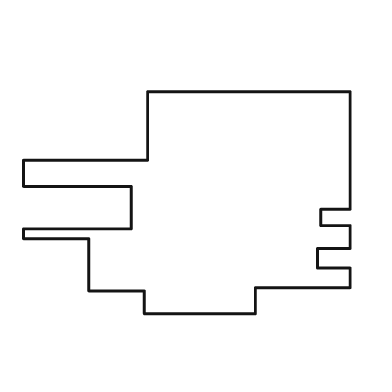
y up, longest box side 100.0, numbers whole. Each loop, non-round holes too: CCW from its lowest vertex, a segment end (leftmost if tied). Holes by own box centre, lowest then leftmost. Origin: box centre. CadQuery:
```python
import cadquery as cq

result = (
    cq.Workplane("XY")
    .moveTo(-13.0, -34.0)
    .lineTo(21.0, -34.0)
    .lineTo(21.0, -26.0)
    .lineTo(50.0, -26.0)
    .lineTo(50.0, -20.0)
    .lineTo(40.0, -20.0)
    .lineTo(40.0, -14.0)
    .lineTo(50.0, -14.0)
    .lineTo(50.0, -7.0)
    .lineTo(41.0, -7.0)
    .lineTo(41.0, -2.0)
    .lineTo(50.0, -2.0)
    .lineTo(50.0, 34.0)
    .lineTo(-12.0, 34.0)
    .lineTo(-12.0, 13.0)
    .lineTo(-50.0, 13.0)
    .lineTo(-50.0, 5.0)
    .lineTo(-17.0, 5.0)
    .lineTo(-17.0, -8.0)
    .lineTo(-50.0, -8.0)
    .lineTo(-50.0, -11.0)
    .lineTo(-30.0, -11.0)
    .lineTo(-30.0, -27.0)
    .lineTo(-13.0, -27.0)
    .close()
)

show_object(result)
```